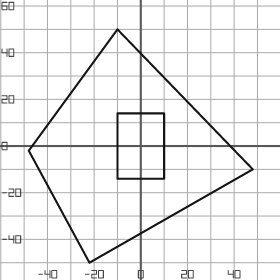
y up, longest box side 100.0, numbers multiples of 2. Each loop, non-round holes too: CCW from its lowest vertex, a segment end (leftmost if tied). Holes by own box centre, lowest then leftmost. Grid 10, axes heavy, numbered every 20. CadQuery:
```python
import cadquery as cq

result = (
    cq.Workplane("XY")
    .moveTo(-22.0, -50.0)
    .lineTo(48.0, -10.0)
    .lineTo(-10.0, 50.0)
    .lineTo(-48.0, -2.0)
    .close()
    .moveTo(-10.0, -14.0)
    .lineTo(10.0, -14.0)
    .lineTo(10.0, 14.0)
    .lineTo(-10.0, 14.0)
    .close()
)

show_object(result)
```